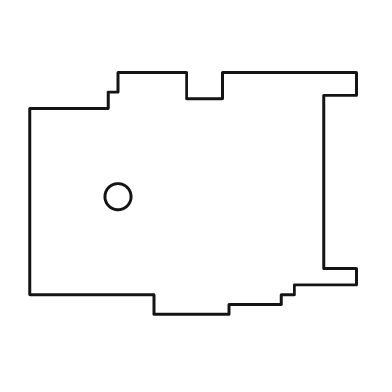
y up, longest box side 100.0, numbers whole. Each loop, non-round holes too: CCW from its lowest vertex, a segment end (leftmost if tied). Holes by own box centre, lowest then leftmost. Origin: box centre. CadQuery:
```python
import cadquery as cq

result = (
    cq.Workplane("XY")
    .moveTo(-12.0, -37.0)
    .lineTo(11.0, -37.0)
    .lineTo(11.0, -34.0)
    .lineTo(27.0, -34.0)
    .lineTo(27.0, -31.0)
    .lineTo(31.0, -31.0)
    .lineTo(31.0, -28.0)
    .lineTo(50.0, -28.0)
    .lineTo(50.0, -23.0)
    .lineTo(40.0, -23.0)
    .lineTo(40.0, 30.0)
    .lineTo(50.0, 30.0)
    .lineTo(50.0, 37.0)
    .lineTo(9.0, 37.0)
    .lineTo(9.0, 29.0)
    .lineTo(-2.0, 29.0)
    .lineTo(-2.0, 37.0)
    .lineTo(-23.0, 37.0)
    .lineTo(-23.0, 31.0)
    .lineTo(-26.0, 31.0)
    .lineTo(-26.0, 26.0)
    .lineTo(-50.0, 26.0)
    .lineTo(-50.0, -31.0)
    .lineTo(-12.0, -31.0)
    .close()
    .moveTo(-23.0, -1.0)
    .circle(4.0)
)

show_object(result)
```